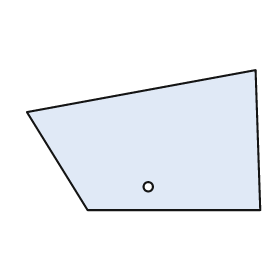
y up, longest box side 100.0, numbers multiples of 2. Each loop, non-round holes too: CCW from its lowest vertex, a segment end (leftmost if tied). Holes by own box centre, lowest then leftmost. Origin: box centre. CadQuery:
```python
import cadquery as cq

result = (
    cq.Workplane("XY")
    .moveTo(-24.0, -30.0)
    .lineTo(50.0, -30.0)
    .lineTo(48.0, 30.0)
    .lineTo(-50.0, 12.0)
    .close()
    .moveTo(2.0, -20.0)
    .circle(2.0)
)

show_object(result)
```